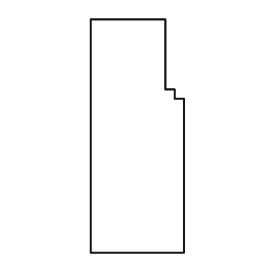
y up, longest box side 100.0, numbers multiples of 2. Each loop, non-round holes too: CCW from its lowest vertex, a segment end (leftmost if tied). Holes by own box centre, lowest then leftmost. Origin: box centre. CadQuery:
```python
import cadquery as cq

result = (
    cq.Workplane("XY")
    .moveTo(-20.0, -50.0)
    .lineTo(20.0, -50.0)
    .lineTo(20.0, 16.0)
    .lineTo(16.0, 16.0)
    .lineTo(16.0, 20.0)
    .lineTo(12.0, 20.0)
    .lineTo(12.0, 50.0)
    .lineTo(-20.0, 50.0)
    .close()
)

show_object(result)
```